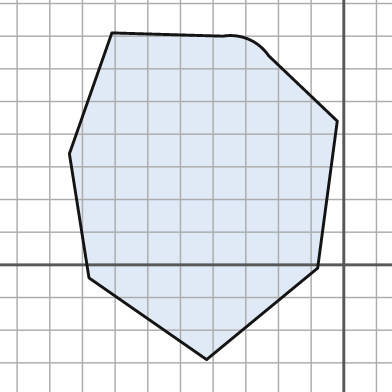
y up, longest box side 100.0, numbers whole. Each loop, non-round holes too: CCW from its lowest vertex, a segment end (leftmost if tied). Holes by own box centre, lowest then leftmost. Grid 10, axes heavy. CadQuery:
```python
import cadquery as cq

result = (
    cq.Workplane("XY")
    .moveTo(-42.0, -29.0)
    .lineTo(-8.0, -1.0)
    .lineTo(-2.0, 44.0)
    .lineTo(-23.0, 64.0)
    .threePointArc((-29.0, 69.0), (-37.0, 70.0))
    .lineTo(-71.0, 71.0)
    .lineTo(-84.0, 34.0)
    .lineTo(-78.0, -4.0)
    .close()
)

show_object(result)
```